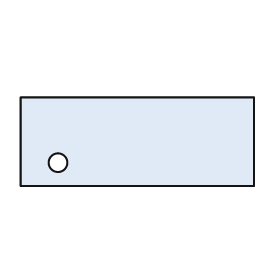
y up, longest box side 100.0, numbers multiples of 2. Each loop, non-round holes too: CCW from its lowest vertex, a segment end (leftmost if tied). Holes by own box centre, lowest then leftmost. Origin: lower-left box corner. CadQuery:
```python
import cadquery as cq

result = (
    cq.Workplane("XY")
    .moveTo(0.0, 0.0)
    .lineTo(100.0, 0.0)
    .lineTo(100.0, 38.0)
    .lineTo(0.0, 38.0)
    .close()
    .moveTo(16.0, 10.0)
    .circle(4.0)
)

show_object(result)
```